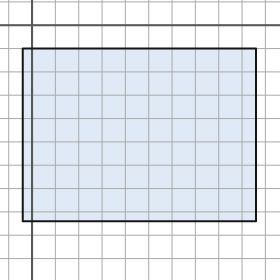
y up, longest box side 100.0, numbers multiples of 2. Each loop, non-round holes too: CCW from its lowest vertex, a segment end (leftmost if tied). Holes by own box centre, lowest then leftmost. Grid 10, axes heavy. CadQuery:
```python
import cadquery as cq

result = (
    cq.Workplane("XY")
    .moveTo(-4.0, -84.0)
    .lineTo(96.0, -84.0)
    .lineTo(96.0, -10.0)
    .lineTo(-4.0, -10.0)
    .close()
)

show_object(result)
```